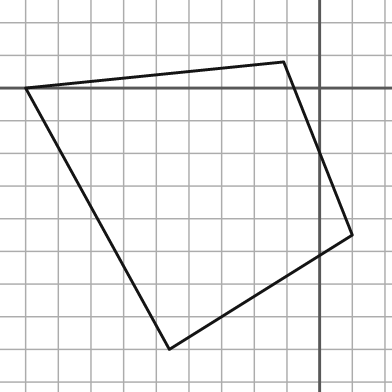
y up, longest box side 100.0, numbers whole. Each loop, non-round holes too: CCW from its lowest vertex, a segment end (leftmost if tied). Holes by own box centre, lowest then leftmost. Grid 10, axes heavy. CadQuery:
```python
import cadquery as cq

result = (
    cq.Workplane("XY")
    .moveTo(-46.0, -80.0)
    .lineTo(10.0, -45.0)
    .lineTo(-11.0, 8.0)
    .lineTo(-90.0, 0.0)
    .close()
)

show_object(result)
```